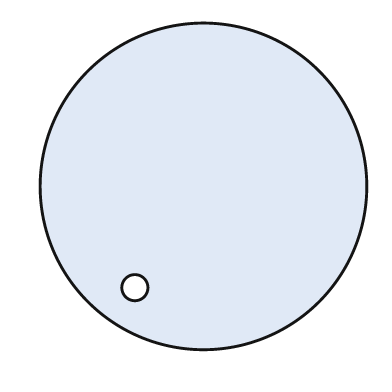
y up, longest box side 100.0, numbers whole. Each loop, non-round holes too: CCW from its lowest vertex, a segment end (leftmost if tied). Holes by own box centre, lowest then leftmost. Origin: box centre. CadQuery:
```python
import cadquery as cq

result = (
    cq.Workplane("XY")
    .moveTo(0.0, 0.0)
    .circle(50.0)
    .moveTo(-21.0, -31.0)
    .circle(4.0)
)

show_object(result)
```